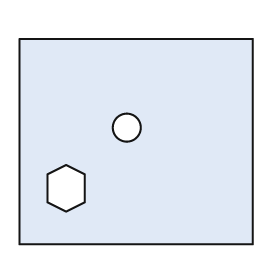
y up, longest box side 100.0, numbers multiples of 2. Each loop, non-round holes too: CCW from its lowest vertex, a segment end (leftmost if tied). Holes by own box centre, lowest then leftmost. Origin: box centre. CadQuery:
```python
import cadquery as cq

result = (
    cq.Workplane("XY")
    .moveTo(-50.0, -44.0)
    .lineTo(50.0, -44.0)
    .lineTo(50.0, 44.0)
    .lineTo(-50.0, 44.0)
    .close()
    .moveTo(-30.0, -30.0)
    .lineTo(-22.0, -26.0)
    .lineTo(-22.0, -14.0)
    .lineTo(-30.0, -10.0)
    .lineTo(-38.0, -14.0)
    .lineTo(-38.0, -26.0)
    .close()
    .moveTo(-4.0, 6.0)
    .circle(6.0)
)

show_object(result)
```